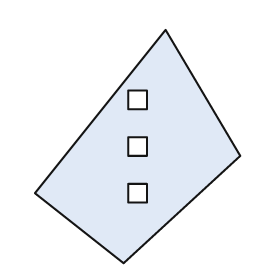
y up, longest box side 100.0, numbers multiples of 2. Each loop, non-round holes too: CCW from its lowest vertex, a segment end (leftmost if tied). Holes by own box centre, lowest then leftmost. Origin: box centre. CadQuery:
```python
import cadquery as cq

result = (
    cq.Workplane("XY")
    .moveTo(-6.0, -50.0)
    .lineTo(44.0, -4.0)
    .lineTo(12.0, 50.0)
    .lineTo(-44.0, -20.0)
    .close()
    .moveTo(-4.0, -24.0)
    .lineTo(4.0, -24.0)
    .lineTo(4.0, -16.0)
    .lineTo(-4.0, -16.0)
    .close()
    .moveTo(-4.0, -4.0)
    .lineTo(4.0, -4.0)
    .lineTo(4.0, 4.0)
    .lineTo(-4.0, 4.0)
    .close()
    .moveTo(-4.0, 16.0)
    .lineTo(4.0, 16.0)
    .lineTo(4.0, 24.0)
    .lineTo(-4.0, 24.0)
    .close()
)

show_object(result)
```